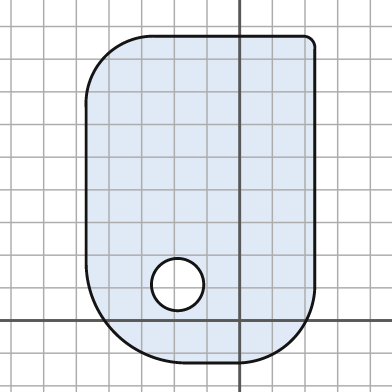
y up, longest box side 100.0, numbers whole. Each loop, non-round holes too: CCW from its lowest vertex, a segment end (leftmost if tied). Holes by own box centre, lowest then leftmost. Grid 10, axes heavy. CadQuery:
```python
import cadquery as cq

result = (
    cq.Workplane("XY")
    .moveTo(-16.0, -13.0)
    .lineTo(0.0, -13.0)
    .threePointArc((16.0, -6.0), (23.0, 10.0))
    .lineTo(23.0, 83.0)
    .threePointArc((22.0, 86.0), (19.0, 87.0))
    .lineTo(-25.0, 87.0)
    .threePointArc((-41.0, 81.0), (-47.0, 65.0))
    .lineTo(-47.0, 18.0)
    .threePointArc((-38.0, -4.0), (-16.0, -13.0))
    .close()
    .moveTo(-19.0, 11.0)
    .circle(8.0)
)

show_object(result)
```